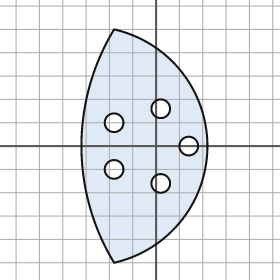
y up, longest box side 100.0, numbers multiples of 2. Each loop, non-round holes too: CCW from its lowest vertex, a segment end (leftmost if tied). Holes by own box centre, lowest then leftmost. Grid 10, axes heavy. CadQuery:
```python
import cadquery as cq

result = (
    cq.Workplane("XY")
    .moveTo(-18.0, -50.0)
    .threePointArc((22.0, 0.0), (-18.0, 50.0))
    .threePointArc((-32.0, 0.0), (-18.0, -50.0))
    .close()
    .moveTo(2.0, -16.0)
    .circle(4.0)
    .moveTo(-18.0, -10.0)
    .circle(4.0)
    .moveTo(14.0, 0.0)
    .circle(4.0)
    .moveTo(-18.0, 10.0)
    .circle(4.0)
    .moveTo(2.0, 16.0)
    .circle(4.0)
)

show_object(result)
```